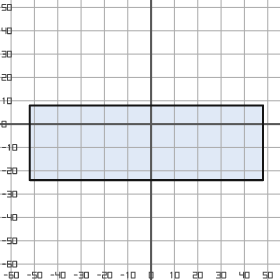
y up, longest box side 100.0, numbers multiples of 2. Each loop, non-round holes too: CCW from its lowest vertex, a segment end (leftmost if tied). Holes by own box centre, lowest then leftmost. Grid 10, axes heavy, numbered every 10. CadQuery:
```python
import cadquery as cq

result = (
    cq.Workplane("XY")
    .moveTo(-52.0, -24.0)
    .lineTo(48.0, -24.0)
    .lineTo(48.0, 8.0)
    .lineTo(-52.0, 8.0)
    .close()
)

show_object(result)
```